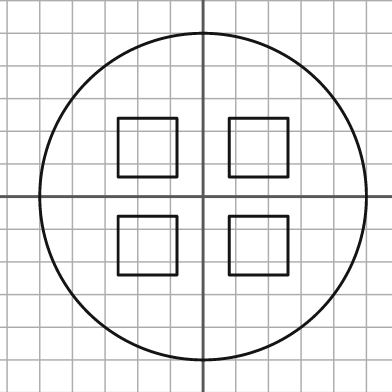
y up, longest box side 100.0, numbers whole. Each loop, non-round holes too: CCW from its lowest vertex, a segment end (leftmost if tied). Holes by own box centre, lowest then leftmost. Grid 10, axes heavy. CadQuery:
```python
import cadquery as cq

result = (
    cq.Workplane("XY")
    .moveTo(0.0, 0.0)
    .circle(50.0)
    .moveTo(-26.0, -24.0)
    .lineTo(-8.0, -24.0)
    .lineTo(-8.0, -6.0)
    .lineTo(-26.0, -6.0)
    .close()
    .moveTo(8.0, -24.0)
    .lineTo(26.0, -24.0)
    .lineTo(26.0, -6.0)
    .lineTo(8.0, -6.0)
    .close()
    .moveTo(-26.0, 6.0)
    .lineTo(-8.0, 6.0)
    .lineTo(-8.0, 24.0)
    .lineTo(-26.0, 24.0)
    .close()
    .moveTo(8.0, 6.0)
    .lineTo(26.0, 6.0)
    .lineTo(26.0, 24.0)
    .lineTo(8.0, 24.0)
    .close()
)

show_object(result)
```